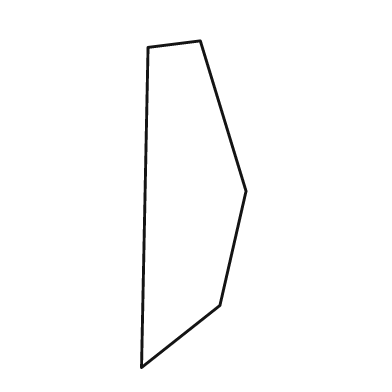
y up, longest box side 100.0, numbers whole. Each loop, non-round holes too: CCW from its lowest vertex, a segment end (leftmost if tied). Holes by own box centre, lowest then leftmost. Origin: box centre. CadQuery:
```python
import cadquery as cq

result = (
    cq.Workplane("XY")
    .moveTo(-16.0, -50.0)
    .lineTo(8.0, -31.0)
    .lineTo(16.0, 4.0)
    .lineTo(2.0, 50.0)
    .lineTo(-14.0, 48.0)
    .close()
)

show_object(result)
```